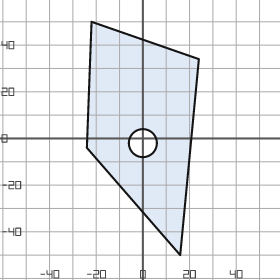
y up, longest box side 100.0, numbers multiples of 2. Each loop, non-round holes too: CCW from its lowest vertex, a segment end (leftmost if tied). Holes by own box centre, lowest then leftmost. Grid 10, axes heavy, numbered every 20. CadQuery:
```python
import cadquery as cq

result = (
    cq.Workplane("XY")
    .moveTo(16.0, -50.0)
    .lineTo(24.0, 34.0)
    .lineTo(-22.0, 50.0)
    .lineTo(-24.0, -4.0)
    .close()
    .moveTo(0.0, -2.0)
    .circle(6.0)
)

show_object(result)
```